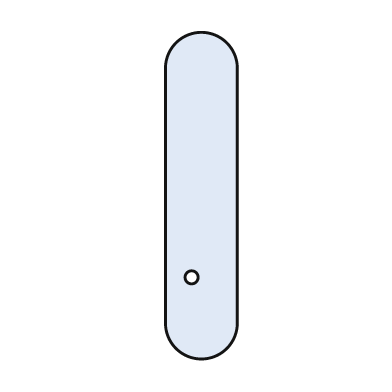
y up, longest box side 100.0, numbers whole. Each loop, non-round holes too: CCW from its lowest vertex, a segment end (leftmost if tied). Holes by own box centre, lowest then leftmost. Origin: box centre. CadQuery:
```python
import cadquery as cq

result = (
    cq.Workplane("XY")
    .moveTo(-11.0, -39.0)
    .threePointArc((0.0, -50.0), (11.0, -39.0))
    .lineTo(11.0, 39.0)
    .threePointArc((0.0, 50.0), (-11.0, 39.0))
    .close()
    .moveTo(-3.0, -25.0)
    .circle(2.0)
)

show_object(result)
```